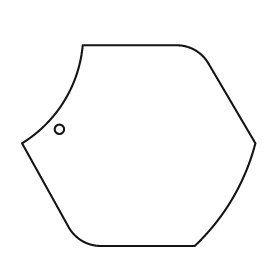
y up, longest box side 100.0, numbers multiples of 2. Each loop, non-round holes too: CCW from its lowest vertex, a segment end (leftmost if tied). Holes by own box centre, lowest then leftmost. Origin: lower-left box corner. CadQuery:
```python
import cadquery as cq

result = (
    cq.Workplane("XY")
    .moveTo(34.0, 0.0)
    .lineTo(74.0, 0.0)
    .threePointArc((90.0, 20.0), (100.0, 44.0))
    .lineTo(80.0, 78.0)
    .threePointArc((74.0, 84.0), (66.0, 86.0))
    .lineTo(26.0, 86.0)
    .threePointArc((18.0, 62.0), (0.0, 44.0))
    .lineTo(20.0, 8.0)
    .threePointArc((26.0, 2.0), (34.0, 0.0))
    .close()
    .moveTo(16.0, 50.0)
    .circle(2.0)
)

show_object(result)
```